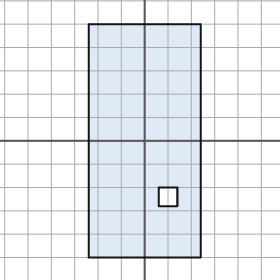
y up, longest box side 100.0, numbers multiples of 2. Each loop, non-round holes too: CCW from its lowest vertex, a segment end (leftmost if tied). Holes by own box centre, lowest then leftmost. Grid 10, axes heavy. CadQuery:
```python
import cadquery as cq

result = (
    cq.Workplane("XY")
    .moveTo(-24.0, -50.0)
    .lineTo(24.0, -50.0)
    .lineTo(24.0, 50.0)
    .lineTo(-24.0, 50.0)
    .close()
    .moveTo(6.0, -28.0)
    .lineTo(14.0, -28.0)
    .lineTo(14.0, -20.0)
    .lineTo(6.0, -20.0)
    .close()
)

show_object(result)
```